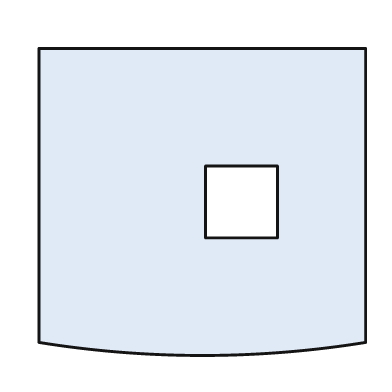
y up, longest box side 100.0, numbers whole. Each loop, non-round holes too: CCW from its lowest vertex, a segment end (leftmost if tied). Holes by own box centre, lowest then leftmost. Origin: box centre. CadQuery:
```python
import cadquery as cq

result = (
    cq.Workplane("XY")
    .moveTo(-50.0, -43.0)
    .threePointArc((0.0, -47.0), (50.0, -43.0))
    .lineTo(50.0, 47.0)
    .lineTo(-50.0, 47.0)
    .close()
    .moveTo(1.0, -11.0)
    .lineTo(23.0, -11.0)
    .lineTo(23.0, 11.0)
    .lineTo(1.0, 11.0)
    .close()
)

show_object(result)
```